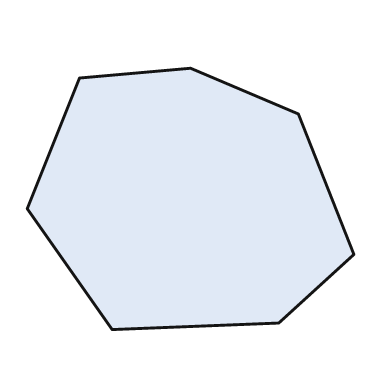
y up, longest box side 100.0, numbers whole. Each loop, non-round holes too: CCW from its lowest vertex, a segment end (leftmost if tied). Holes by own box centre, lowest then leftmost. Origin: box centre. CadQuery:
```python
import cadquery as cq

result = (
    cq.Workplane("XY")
    .moveTo(-24.0, -40.0)
    .lineTo(27.0, -38.0)
    .lineTo(50.0, -17.0)
    .lineTo(33.0, 26.0)
    .lineTo(0.0, 40.0)
    .lineTo(-34.0, 37.0)
    .lineTo(-50.0, -3.0)
    .close()
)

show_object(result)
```